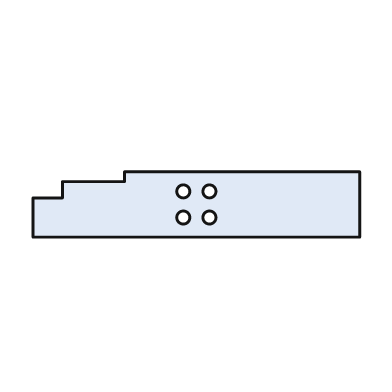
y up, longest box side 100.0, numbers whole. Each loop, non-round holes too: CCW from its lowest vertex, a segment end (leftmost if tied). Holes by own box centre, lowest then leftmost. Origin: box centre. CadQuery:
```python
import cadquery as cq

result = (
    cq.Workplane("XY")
    .moveTo(-50.0, -10.0)
    .lineTo(50.0, -10.0)
    .lineTo(50.0, 10.0)
    .lineTo(-22.0, 10.0)
    .lineTo(-22.0, 7.0)
    .lineTo(-41.0, 7.0)
    .lineTo(-41.0, 2.0)
    .lineTo(-50.0, 2.0)
    .close()
    .moveTo(-4.0, -4.0)
    .circle(2.0)
    .moveTo(4.0, -4.0)
    .circle(2.0)
    .moveTo(-4.0, 4.0)
    .circle(2.0)
    .moveTo(4.0, 4.0)
    .circle(2.0)
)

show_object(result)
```